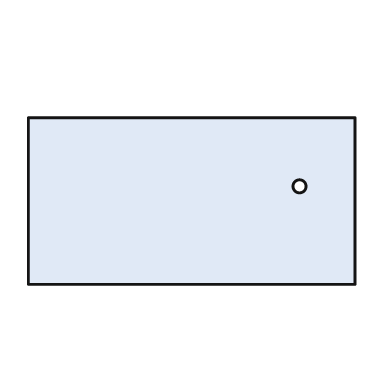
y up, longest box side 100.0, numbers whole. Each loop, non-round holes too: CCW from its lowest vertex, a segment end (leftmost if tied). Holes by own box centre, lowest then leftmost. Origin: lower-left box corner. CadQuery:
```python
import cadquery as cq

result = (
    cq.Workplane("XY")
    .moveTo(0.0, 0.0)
    .lineTo(100.0, 0.0)
    .lineTo(100.0, 51.0)
    .lineTo(0.0, 51.0)
    .close()
    .moveTo(83.0, 30.0)
    .circle(2.0)
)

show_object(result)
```